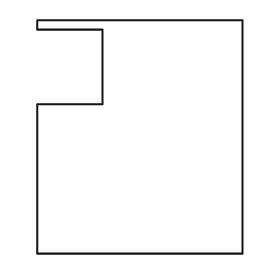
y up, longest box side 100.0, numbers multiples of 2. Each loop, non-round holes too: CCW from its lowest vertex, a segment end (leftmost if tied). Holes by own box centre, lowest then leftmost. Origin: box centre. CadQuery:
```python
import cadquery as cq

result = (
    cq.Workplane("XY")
    .moveTo(-44.0, -50.0)
    .lineTo(44.0, -50.0)
    .lineTo(44.0, 50.0)
    .lineTo(-44.0, 50.0)
    .lineTo(-44.0, 46.0)
    .lineTo(-16.0, 46.0)
    .lineTo(-16.0, 14.0)
    .lineTo(-44.0, 14.0)
    .close()
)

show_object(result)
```